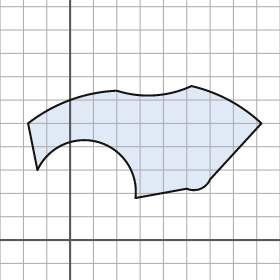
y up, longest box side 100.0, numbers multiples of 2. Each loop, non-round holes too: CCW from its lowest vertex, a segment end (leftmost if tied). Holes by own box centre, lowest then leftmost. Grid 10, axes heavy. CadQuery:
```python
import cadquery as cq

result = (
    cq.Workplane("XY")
    .moveTo(28.0, 18.0)
    .lineTo(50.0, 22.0)
    .threePointArc((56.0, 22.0), (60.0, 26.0))
    .lineTo(82.0, 50.0)
    .threePointArc((68.0, 60.0), (52.0, 66.0))
    .threePointArc((36.0, 62.0), (20.0, 64.0))
    .threePointArc((0.0, 60.0), (-18.0, 50.0))
    .lineTo(-14.0, 30.0)
    .threePointArc((12.0, 42.0), (28.0, 18.0))
    .close()
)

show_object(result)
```